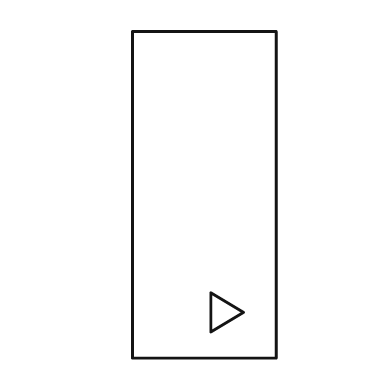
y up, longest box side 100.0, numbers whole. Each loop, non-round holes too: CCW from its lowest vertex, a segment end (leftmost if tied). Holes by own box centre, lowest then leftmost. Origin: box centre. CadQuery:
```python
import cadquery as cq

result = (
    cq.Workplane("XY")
    .moveTo(-22.0, -50.0)
    .lineTo(22.0, -50.0)
    .lineTo(22.0, 50.0)
    .lineTo(-22.0, 50.0)
    .close()
    .moveTo(2.0, -42.0)
    .lineTo(12.0, -36.0)
    .lineTo(2.0, -30.0)
    .close()
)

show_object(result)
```